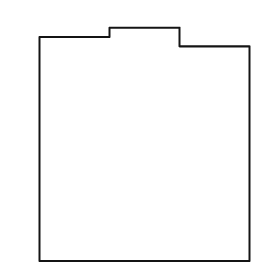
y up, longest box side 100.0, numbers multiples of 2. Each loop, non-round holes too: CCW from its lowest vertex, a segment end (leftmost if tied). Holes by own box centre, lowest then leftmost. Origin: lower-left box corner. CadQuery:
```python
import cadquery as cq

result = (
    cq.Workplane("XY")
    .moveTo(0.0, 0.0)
    .lineTo(90.0, 0.0)
    .lineTo(90.0, 92.0)
    .lineTo(60.0, 92.0)
    .lineTo(60.0, 100.0)
    .lineTo(30.0, 100.0)
    .lineTo(30.0, 96.0)
    .lineTo(0.0, 96.0)
    .close()
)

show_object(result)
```